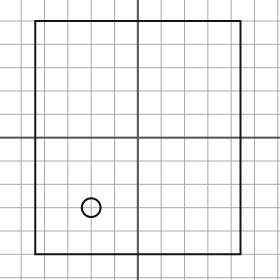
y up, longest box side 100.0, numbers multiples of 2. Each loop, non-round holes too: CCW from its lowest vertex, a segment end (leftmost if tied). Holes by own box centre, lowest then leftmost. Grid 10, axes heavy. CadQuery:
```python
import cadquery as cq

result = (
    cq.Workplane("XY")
    .moveTo(-44.0, -50.0)
    .lineTo(44.0, -50.0)
    .lineTo(44.0, 50.0)
    .lineTo(-44.0, 50.0)
    .close()
    .moveTo(-20.0, -30.0)
    .circle(4.0)
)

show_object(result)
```